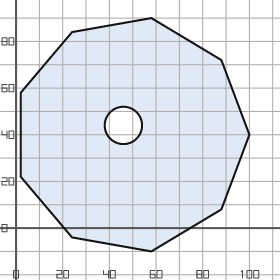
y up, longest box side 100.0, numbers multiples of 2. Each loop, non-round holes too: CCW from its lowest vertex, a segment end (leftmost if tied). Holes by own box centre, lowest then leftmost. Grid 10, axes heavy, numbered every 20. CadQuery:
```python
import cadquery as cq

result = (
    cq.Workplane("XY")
    .moveTo(58.0, -10.0)
    .lineTo(88.0, 8.0)
    .lineTo(100.0, 40.0)
    .lineTo(88.0, 72.0)
    .lineTo(58.0, 90.0)
    .lineTo(24.0, 84.0)
    .lineTo(2.0, 58.0)
    .lineTo(2.0, 22.0)
    .lineTo(24.0, -4.0)
    .close()
    .moveTo(46.0, 44.0)
    .circle(8.0)
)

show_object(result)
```